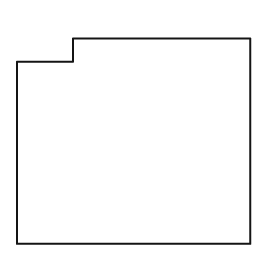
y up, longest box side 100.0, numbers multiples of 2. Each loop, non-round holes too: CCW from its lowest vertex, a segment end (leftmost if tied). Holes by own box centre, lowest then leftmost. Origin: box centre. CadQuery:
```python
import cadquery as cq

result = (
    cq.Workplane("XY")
    .moveTo(-50.0, -44.0)
    .lineTo(50.0, -44.0)
    .lineTo(50.0, 44.0)
    .lineTo(-26.0, 44.0)
    .lineTo(-26.0, 34.0)
    .lineTo(-50.0, 34.0)
    .close()
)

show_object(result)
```